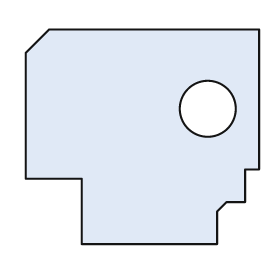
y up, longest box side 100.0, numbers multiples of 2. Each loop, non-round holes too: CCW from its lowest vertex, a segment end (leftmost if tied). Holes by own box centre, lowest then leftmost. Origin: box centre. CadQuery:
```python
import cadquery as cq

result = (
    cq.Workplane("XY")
    .moveTo(-26.0, -46.0)
    .lineTo(32.0, -46.0)
    .lineTo(32.0, -32.0)
    .lineTo(36.0, -28.0)
    .lineTo(44.0, -28.0)
    .lineTo(44.0, -14.0)
    .lineTo(50.0, -14.0)
    .lineTo(50.0, 46.0)
    .lineTo(-40.0, 46.0)
    .lineTo(-50.0, 36.0)
    .lineTo(-50.0, -18.0)
    .lineTo(-26.0, -18.0)
    .close()
    .moveTo(28.0, 12.0)
    .circle(12.0)
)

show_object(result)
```